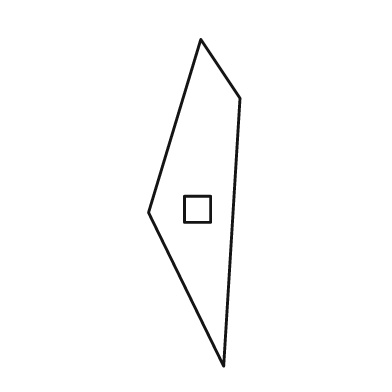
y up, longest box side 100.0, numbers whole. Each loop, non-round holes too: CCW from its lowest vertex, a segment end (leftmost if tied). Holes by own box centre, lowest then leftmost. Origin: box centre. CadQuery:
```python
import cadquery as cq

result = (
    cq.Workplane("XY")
    .moveTo(9.0, -50.0)
    .lineTo(14.0, 32.0)
    .lineTo(2.0, 50.0)
    .lineTo(-14.0, -3.0)
    .close()
    .moveTo(-3.0, -6.0)
    .lineTo(5.0, -6.0)
    .lineTo(5.0, 2.0)
    .lineTo(-3.0, 2.0)
    .close()
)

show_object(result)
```